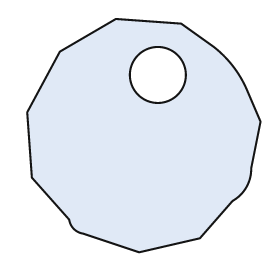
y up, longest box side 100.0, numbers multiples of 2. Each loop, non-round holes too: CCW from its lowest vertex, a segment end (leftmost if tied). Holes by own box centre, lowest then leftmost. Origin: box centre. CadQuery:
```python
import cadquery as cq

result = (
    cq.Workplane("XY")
    .moveTo(-2.0, -50.0)
    .lineTo(24.0, -44.0)
    .lineTo(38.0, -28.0)
    .threePointArc((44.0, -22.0), (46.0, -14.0))
    .lineTo(50.0, 6.0)
    .lineTo(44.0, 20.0)
    .threePointArc((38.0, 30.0), (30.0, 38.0))
    .lineTo(16.0, 48.0)
    .lineTo(-12.0, 50.0)
    .lineTo(-36.0, 36.0)
    .lineTo(-50.0, 10.0)
    .lineTo(-48.0, -18.0)
    .lineTo(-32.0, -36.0)
    .threePointArc((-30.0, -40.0), (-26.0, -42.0))
    .close()
    .moveTo(6.0, 26.0)
    .circle(12.0)
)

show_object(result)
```